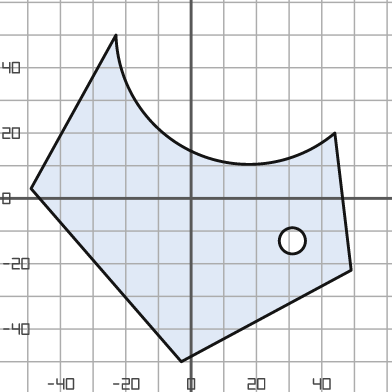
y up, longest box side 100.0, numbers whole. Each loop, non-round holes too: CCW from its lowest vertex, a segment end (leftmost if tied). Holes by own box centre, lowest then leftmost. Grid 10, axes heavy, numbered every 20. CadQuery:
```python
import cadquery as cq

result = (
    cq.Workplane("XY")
    .moveTo(-3.0, -50.0)
    .lineTo(49.0, -22.0)
    .lineTo(44.0, 20.0)
    .threePointArc((1.0, 14.0), (-23.0, 50.0))
    .lineTo(-49.0, 3.0)
    .close()
    .moveTo(31.0, -13.0)
    .circle(4.0)
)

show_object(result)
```